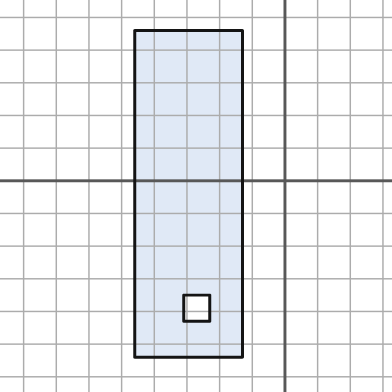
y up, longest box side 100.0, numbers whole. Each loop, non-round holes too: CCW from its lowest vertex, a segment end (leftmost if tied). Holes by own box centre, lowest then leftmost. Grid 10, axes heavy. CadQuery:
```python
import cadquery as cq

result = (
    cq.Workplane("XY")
    .moveTo(-46.0, -54.0)
    .lineTo(-13.0, -54.0)
    .lineTo(-13.0, 46.0)
    .lineTo(-46.0, 46.0)
    .close()
    .moveTo(-31.0, -43.0)
    .lineTo(-23.0, -43.0)
    .lineTo(-23.0, -35.0)
    .lineTo(-31.0, -35.0)
    .close()
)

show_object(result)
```